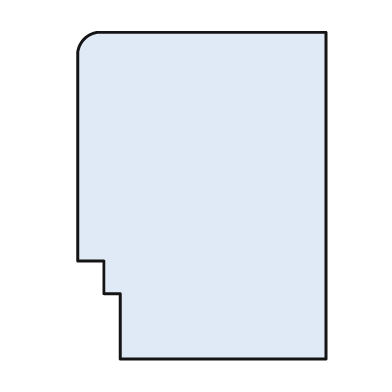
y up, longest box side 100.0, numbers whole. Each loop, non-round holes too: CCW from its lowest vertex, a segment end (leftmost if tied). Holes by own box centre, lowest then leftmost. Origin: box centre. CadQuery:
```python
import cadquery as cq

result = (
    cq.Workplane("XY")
    .moveTo(-25.0, -50.0)
    .lineTo(38.0, -50.0)
    .lineTo(38.0, 50.0)
    .lineTo(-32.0, 50.0)
    .threePointArc((-36.0, 48.0), (-38.0, 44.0))
    .lineTo(-38.0, -20.0)
    .lineTo(-30.0, -20.0)
    .lineTo(-30.0, -30.0)
    .lineTo(-25.0, -30.0)
    .close()
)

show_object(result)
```